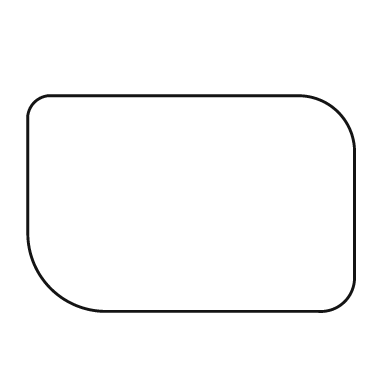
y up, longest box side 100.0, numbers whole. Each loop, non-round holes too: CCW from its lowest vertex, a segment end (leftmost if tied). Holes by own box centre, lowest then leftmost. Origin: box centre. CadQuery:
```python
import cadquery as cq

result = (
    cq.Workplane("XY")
    .moveTo(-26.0, -33.0)
    .lineTo(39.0, -33.0)
    .threePointArc((47.0, -30.0), (50.0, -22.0))
    .lineTo(50.0, 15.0)
    .threePointArc((45.0, 28.0), (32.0, 33.0))
    .lineTo(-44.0, 33.0)
    .threePointArc((-48.0, 31.0), (-50.0, 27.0))
    .lineTo(-50.0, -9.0)
    .threePointArc((-43.0, -26.0), (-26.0, -33.0))
    .close()
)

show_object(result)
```